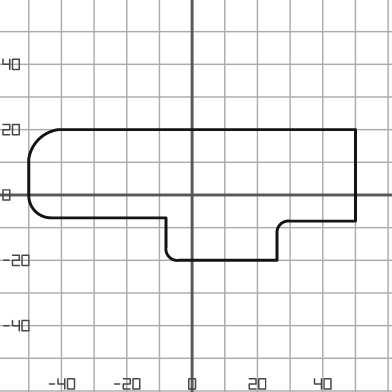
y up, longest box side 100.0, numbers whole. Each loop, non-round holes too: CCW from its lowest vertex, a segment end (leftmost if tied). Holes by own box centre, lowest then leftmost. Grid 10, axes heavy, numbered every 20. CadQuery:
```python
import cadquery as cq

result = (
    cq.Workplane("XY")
    .moveTo(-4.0, -20.0)
    .lineTo(26.0, -20.0)
    .lineTo(26.0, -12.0)
    .threePointArc((27.0, -9.0), (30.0, -8.0))
    .lineTo(50.0, -8.0)
    .lineTo(50.0, 20.0)
    .lineTo(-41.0, 20.0)
    .threePointArc((-47.0, 17.0), (-50.0, 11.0))
    .lineTo(-50.0, 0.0)
    .threePointArc((-48.0, -5.0), (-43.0, -7.0))
    .lineTo(-8.0, -7.0)
    .lineTo(-8.0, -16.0)
    .threePointArc((-7.0, -19.0), (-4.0, -20.0))
    .close()
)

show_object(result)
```